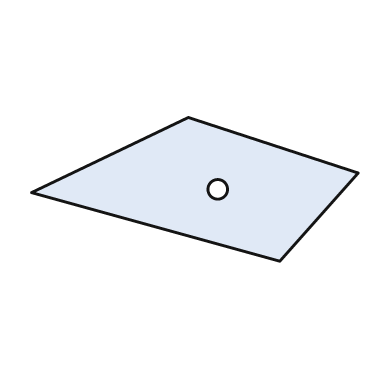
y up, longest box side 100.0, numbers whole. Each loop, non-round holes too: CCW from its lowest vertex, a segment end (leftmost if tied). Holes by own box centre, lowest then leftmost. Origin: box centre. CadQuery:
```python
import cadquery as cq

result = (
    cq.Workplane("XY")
    .moveTo(26.0, -22.0)
    .lineTo(50.0, 5.0)
    .lineTo(-2.0, 22.0)
    .lineTo(-50.0, -1.0)
    .close()
    .moveTo(7.0, 0.0)
    .circle(3.0)
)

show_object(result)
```